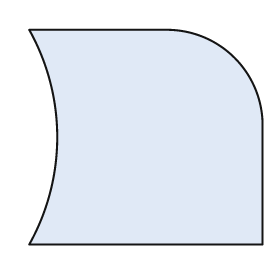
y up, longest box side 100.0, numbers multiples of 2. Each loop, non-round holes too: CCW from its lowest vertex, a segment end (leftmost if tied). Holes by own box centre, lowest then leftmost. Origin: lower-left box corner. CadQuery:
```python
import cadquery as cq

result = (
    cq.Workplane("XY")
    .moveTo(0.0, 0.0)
    .lineTo(100.0, 0.0)
    .lineTo(100.0, 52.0)
    .threePointArc((88.0, 80.0), (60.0, 92.0))
    .lineTo(0.0, 92.0)
    .threePointArc((12.0, 46.0), (0.0, 0.0))
    .close()
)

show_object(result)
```